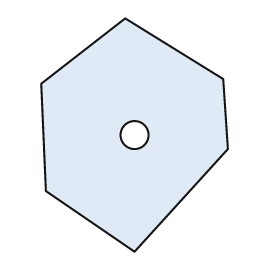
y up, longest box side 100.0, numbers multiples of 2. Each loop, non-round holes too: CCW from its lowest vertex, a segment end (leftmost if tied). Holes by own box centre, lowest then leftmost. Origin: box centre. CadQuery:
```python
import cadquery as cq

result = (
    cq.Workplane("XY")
    .moveTo(0.0, -50.0)
    .lineTo(40.0, -6.0)
    .lineTo(38.0, 24.0)
    .lineTo(-4.0, 50.0)
    .lineTo(-40.0, 22.0)
    .lineTo(-38.0, -24.0)
    .close()
    .moveTo(0.0, 0.0)
    .circle(6.0)
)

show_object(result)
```